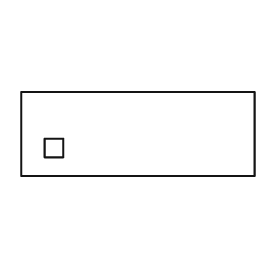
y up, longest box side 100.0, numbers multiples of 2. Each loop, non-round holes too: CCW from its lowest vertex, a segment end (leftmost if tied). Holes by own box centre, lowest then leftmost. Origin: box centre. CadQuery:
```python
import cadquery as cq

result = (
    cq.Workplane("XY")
    .moveTo(-50.0, -18.0)
    .lineTo(50.0, -18.0)
    .lineTo(50.0, 18.0)
    .lineTo(-50.0, 18.0)
    .close()
    .moveTo(-40.0, -10.0)
    .lineTo(-32.0, -10.0)
    .lineTo(-32.0, -2.0)
    .lineTo(-40.0, -2.0)
    .close()
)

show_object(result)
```